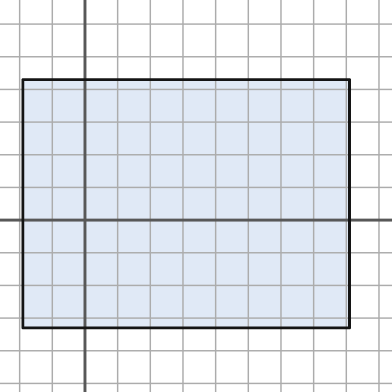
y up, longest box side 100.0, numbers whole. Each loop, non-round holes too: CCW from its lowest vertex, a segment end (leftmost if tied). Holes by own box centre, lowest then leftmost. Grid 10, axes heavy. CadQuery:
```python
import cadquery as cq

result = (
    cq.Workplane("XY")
    .moveTo(-19.0, -33.0)
    .lineTo(81.0, -33.0)
    .lineTo(81.0, 43.0)
    .lineTo(-19.0, 43.0)
    .close()
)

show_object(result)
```